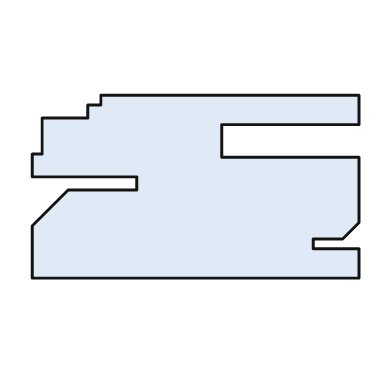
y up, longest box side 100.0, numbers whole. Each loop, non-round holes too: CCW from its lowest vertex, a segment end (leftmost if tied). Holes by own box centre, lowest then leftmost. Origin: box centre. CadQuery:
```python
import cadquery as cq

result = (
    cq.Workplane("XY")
    .moveTo(-50.0, -28.0)
    .lineTo(50.0, -28.0)
    .lineTo(50.0, -19.0)
    .lineTo(36.0, -19.0)
    .lineTo(36.0, -16.0)
    .lineTo(45.0, -16.0)
    .lineTo(50.0, -11.0)
    .lineTo(50.0, 9.0)
    .lineTo(8.0, 9.0)
    .lineTo(8.0, 19.0)
    .lineTo(50.0, 19.0)
    .lineTo(50.0, 28.0)
    .lineTo(-29.0, 28.0)
    .lineTo(-29.0, 25.0)
    .lineTo(-33.0, 25.0)
    .lineTo(-33.0, 21.0)
    .lineTo(-47.0, 21.0)
    .lineTo(-47.0, 10.0)
    .lineTo(-50.0, 10.0)
    .lineTo(-50.0, 3.0)
    .lineTo(-18.0, 3.0)
    .lineTo(-18.0, -1.0)
    .lineTo(-39.0, -1.0)
    .lineTo(-50.0, -12.0)
    .close()
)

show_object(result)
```